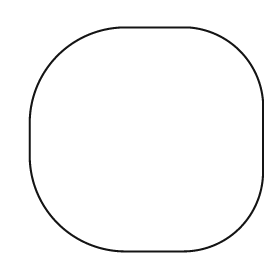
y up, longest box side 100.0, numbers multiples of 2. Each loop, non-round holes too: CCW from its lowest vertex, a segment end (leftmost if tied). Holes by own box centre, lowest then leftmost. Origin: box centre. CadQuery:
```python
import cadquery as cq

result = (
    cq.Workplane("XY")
    .moveTo(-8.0, -48.0)
    .lineTo(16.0, -48.0)
    .threePointArc((40.0, -38.0), (50.0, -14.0))
    .lineTo(50.0, 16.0)
    .threePointArc((40.0, 38.0), (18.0, 48.0))
    .lineTo(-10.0, 48.0)
    .threePointArc((-38.0, 36.0), (-50.0, 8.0))
    .lineTo(-50.0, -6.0)
    .threePointArc((-38.0, -36.0), (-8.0, -48.0))
    .close()
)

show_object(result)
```